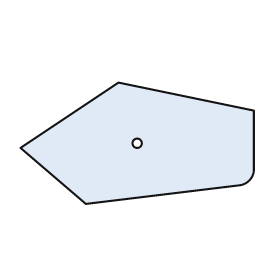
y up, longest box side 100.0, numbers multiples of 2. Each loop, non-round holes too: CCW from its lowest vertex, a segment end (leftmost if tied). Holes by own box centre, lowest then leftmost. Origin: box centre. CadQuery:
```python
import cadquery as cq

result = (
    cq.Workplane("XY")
    .moveTo(-22.0, -26.0)
    .lineTo(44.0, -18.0)
    .threePointArc((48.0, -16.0), (50.0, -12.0))
    .lineTo(50.0, 14.0)
    .lineTo(-8.0, 26.0)
    .lineTo(-50.0, -2.0)
    .close()
    .moveTo(0.0, 0.0)
    .circle(2.0)
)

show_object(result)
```